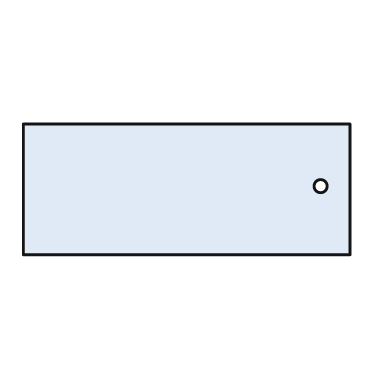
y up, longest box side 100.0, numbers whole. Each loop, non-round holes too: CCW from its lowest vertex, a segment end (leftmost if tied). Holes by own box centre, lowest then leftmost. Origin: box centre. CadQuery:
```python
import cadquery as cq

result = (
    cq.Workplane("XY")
    .moveTo(-50.0, -20.0)
    .lineTo(50.0, -20.0)
    .lineTo(50.0, 20.0)
    .lineTo(-50.0, 20.0)
    .close()
    .moveTo(41.0, 1.0)
    .circle(2.0)
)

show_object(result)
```